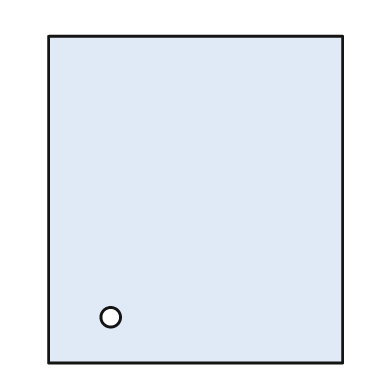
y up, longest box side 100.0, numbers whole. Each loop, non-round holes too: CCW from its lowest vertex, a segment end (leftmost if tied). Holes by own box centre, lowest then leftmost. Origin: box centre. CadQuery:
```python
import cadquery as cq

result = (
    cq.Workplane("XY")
    .moveTo(-45.0, -50.0)
    .lineTo(45.0, -50.0)
    .lineTo(45.0, 50.0)
    .lineTo(-45.0, 50.0)
    .close()
    .moveTo(-26.0, -36.0)
    .circle(3.0)
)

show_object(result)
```